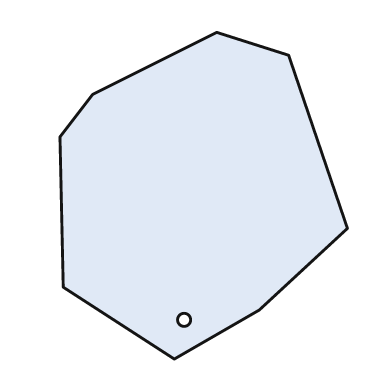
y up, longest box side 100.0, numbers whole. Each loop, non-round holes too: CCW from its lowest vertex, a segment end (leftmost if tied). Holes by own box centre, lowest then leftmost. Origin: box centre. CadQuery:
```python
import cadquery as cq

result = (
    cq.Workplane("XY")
    .moveTo(-9.0, -50.0)
    .lineTo(17.0, -35.0)
    .lineTo(44.0, -10.0)
    .lineTo(26.0, 43.0)
    .lineTo(4.0, 50.0)
    .lineTo(-34.0, 31.0)
    .lineTo(-44.0, 18.0)
    .lineTo(-43.0, -28.0)
    .close()
    .moveTo(-6.0, -38.0)
    .circle(2.0)
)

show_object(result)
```